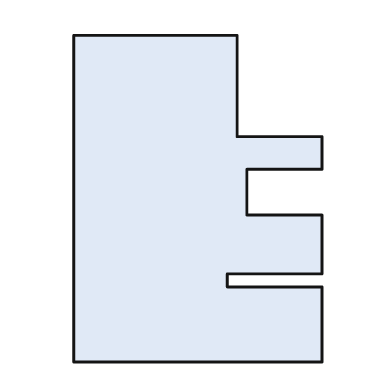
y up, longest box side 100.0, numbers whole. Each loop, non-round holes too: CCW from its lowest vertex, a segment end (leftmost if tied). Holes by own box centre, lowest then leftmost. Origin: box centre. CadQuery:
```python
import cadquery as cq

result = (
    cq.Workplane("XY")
    .moveTo(-38.0, -50.0)
    .lineTo(38.0, -50.0)
    .lineTo(38.0, -27.0)
    .lineTo(9.0, -27.0)
    .lineTo(9.0, -23.0)
    .lineTo(38.0, -23.0)
    .lineTo(38.0, -5.0)
    .lineTo(15.0, -5.0)
    .lineTo(15.0, 9.0)
    .lineTo(38.0, 9.0)
    .lineTo(38.0, 19.0)
    .lineTo(12.0, 19.0)
    .lineTo(12.0, 50.0)
    .lineTo(-38.0, 50.0)
    .close()
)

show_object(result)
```